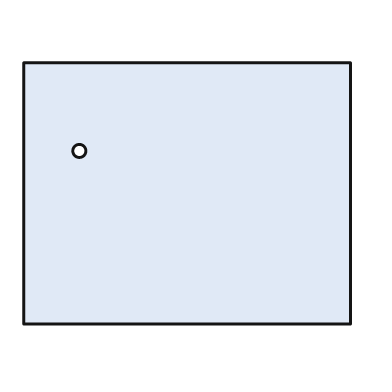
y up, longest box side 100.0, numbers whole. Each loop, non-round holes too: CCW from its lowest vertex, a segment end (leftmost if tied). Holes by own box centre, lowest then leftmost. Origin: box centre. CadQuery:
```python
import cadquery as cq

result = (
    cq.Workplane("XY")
    .moveTo(-50.0, -40.0)
    .lineTo(50.0, -40.0)
    .lineTo(50.0, 40.0)
    .lineTo(-50.0, 40.0)
    .close()
    .moveTo(-33.0, 13.0)
    .circle(2.0)
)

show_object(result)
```